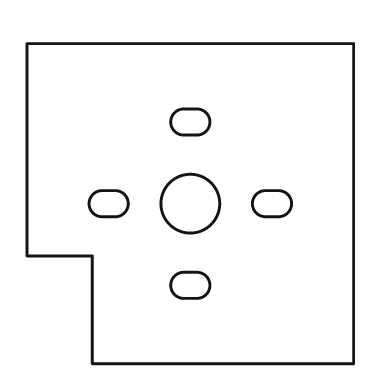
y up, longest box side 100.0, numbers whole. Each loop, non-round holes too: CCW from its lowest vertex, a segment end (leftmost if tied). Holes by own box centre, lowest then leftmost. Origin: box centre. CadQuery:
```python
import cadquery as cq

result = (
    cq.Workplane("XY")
    .moveTo(-30.0, -49.0)
    .lineTo(50.0, -49.0)
    .lineTo(50.0, 49.0)
    .lineTo(-50.0, 49.0)
    .lineTo(-50.0, -16.0)
    .lineTo(-30.0, -16.0)
    .close()
    .moveTo(-2.0, -29.0)
    .lineTo(2.0, -29.0)
    .threePointArc((6.0, -25.0), (2.0, -21.0))
    .lineTo(-2.0, -21.0)
    .threePointArc((-6.0, -25.0), (-2.0, -29.0))
    .close()
    .moveTo(-27.0, -4.0)
    .lineTo(-23.0, -4.0)
    .threePointArc((-19.0, 0.0), (-23.0, 4.0))
    .lineTo(-27.0, 4.0)
    .threePointArc((-31.0, 0.0), (-27.0, -4.0))
    .close()
    .moveTo(0.0, 0.0)
    .circle(9.0)
    .moveTo(23.0, -4.0)
    .lineTo(27.0, -4.0)
    .threePointArc((31.0, 0.0), (27.0, 4.0))
    .lineTo(23.0, 4.0)
    .threePointArc((19.0, 0.0), (23.0, -4.0))
    .close()
    .moveTo(-2.0, 21.0)
    .lineTo(2.0, 21.0)
    .threePointArc((6.0, 25.0), (2.0, 29.0))
    .lineTo(-2.0, 29.0)
    .threePointArc((-6.0, 25.0), (-2.0, 21.0))
    .close()
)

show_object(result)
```